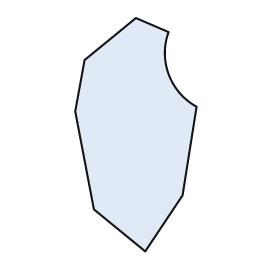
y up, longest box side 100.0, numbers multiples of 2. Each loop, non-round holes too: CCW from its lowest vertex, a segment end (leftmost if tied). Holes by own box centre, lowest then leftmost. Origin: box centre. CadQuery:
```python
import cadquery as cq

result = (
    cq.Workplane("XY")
    .moveTo(4.0, -50.0)
    .lineTo(20.0, -26.0)
    .lineTo(26.0, 12.0)
    .threePointArc((14.0, 26.0), (14.0, 44.0))
    .lineTo(0.0, 50.0)
    .lineTo(-22.0, 32.0)
    .lineTo(-26.0, 10.0)
    .lineTo(-18.0, -32.0)
    .close()
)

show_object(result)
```